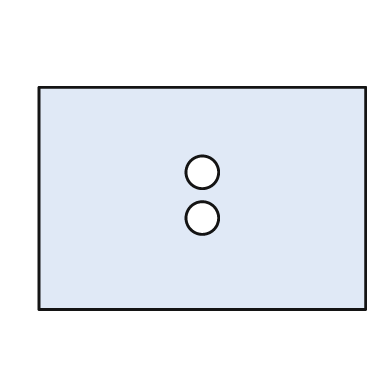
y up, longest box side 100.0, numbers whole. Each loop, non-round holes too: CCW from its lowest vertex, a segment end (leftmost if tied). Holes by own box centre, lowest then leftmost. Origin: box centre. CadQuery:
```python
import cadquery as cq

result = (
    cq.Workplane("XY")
    .moveTo(-50.0, -34.0)
    .lineTo(50.0, -34.0)
    .lineTo(50.0, 34.0)
    .lineTo(-50.0, 34.0)
    .close()
    .moveTo(0.0, -6.0)
    .circle(5.0)
    .moveTo(0.0, 8.0)
    .circle(5.0)
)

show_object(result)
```